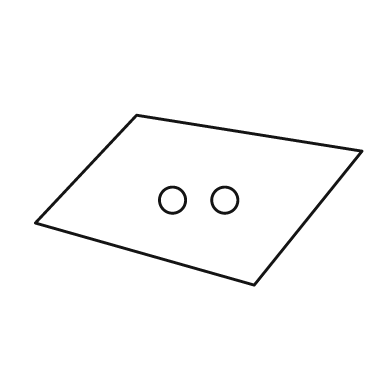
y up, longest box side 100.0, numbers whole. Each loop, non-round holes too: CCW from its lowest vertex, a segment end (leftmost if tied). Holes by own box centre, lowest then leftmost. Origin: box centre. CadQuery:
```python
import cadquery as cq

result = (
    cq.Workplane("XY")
    .moveTo(17.0, -26.0)
    .lineTo(50.0, 15.0)
    .lineTo(-19.0, 26.0)
    .lineTo(-50.0, -7.0)
    .close()
    .moveTo(-8.0, 0.0)
    .circle(4.0)
    .moveTo(8.0, 0.0)
    .circle(4.0)
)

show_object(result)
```